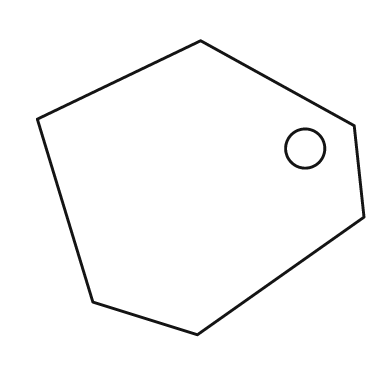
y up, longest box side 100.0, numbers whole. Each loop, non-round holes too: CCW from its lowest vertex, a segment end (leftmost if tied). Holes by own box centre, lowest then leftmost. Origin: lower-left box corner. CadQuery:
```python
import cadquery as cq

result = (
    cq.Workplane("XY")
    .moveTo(49.0, 0.0)
    .lineTo(100.0, 36.0)
    .lineTo(97.0, 64.0)
    .lineTo(50.0, 90.0)
    .lineTo(0.0, 66.0)
    .lineTo(17.0, 10.0)
    .close()
    .moveTo(82.0, 57.0)
    .circle(6.0)
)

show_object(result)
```